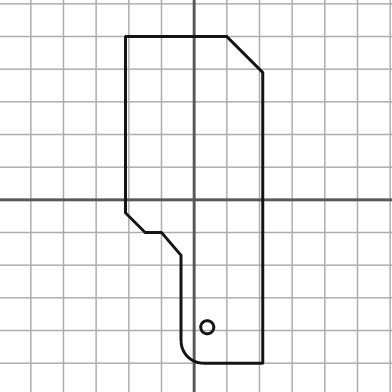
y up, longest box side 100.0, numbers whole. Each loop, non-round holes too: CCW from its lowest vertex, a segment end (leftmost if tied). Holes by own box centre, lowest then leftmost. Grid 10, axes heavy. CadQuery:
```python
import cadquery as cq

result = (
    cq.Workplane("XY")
    .moveTo(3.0, -50.0)
    .lineTo(21.0, -50.0)
    .lineTo(21.0, 39.0)
    .lineTo(10.0, 50.0)
    .lineTo(-21.0, 50.0)
    .lineTo(-21.0, -4.0)
    .lineTo(-15.0, -10.0)
    .lineTo(-10.0, -10.0)
    .lineTo(-4.0, -17.0)
    .lineTo(-4.0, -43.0)
    .threePointArc((-2.0, -48.0), (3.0, -50.0))
    .close()
    .moveTo(4.0, -39.0)
    .circle(2.0)
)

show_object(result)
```